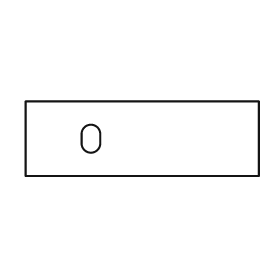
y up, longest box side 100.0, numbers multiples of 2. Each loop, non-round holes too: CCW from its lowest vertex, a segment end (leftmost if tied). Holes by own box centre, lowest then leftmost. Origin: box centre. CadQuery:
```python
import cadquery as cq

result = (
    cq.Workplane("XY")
    .moveTo(-50.0, -16.0)
    .lineTo(50.0, -16.0)
    .lineTo(50.0, 16.0)
    .lineTo(-50.0, 16.0)
    .close()
    .moveTo(-26.0, -2.0)
    .threePointArc((-22.0, -6.0), (-18.0, -2.0))
    .lineTo(-18.0, 2.0)
    .threePointArc((-22.0, 6.0), (-26.0, 2.0))
    .close()
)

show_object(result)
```